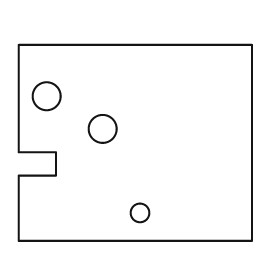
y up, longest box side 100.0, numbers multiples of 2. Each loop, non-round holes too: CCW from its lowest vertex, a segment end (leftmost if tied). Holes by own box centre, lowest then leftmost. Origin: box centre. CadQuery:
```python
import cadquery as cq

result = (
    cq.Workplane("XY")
    .moveTo(-50.0, -42.0)
    .lineTo(50.0, -42.0)
    .lineTo(50.0, 42.0)
    .lineTo(-50.0, 42.0)
    .lineTo(-50.0, -4.0)
    .lineTo(-34.0, -4.0)
    .lineTo(-34.0, -14.0)
    .lineTo(-50.0, -14.0)
    .close()
    .moveTo(2.0, -30.0)
    .circle(4.0)
    .moveTo(-14.0, 6.0)
    .circle(6.0)
    .moveTo(-38.0, 20.0)
    .circle(6.0)
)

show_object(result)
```